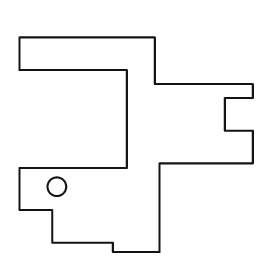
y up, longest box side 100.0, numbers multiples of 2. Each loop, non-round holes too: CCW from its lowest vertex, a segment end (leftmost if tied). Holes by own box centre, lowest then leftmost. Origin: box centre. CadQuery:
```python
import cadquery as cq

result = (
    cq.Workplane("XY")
    .moveTo(-10.0, -46.0)
    .lineTo(10.0, -46.0)
    .lineTo(10.0, -8.0)
    .lineTo(50.0, -8.0)
    .lineTo(50.0, 6.0)
    .lineTo(38.0, 6.0)
    .lineTo(38.0, 20.0)
    .lineTo(50.0, 20.0)
    .lineTo(50.0, 26.0)
    .lineTo(8.0, 26.0)
    .lineTo(8.0, 46.0)
    .lineTo(-50.0, 46.0)
    .lineTo(-50.0, 32.0)
    .lineTo(-4.0, 32.0)
    .lineTo(-4.0, -10.0)
    .lineTo(-50.0, -10.0)
    .lineTo(-50.0, -28.0)
    .lineTo(-36.0, -28.0)
    .lineTo(-36.0, -42.0)
    .lineTo(-10.0, -42.0)
    .close()
    .moveTo(-34.0, -18.0)
    .circle(4.0)
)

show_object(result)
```